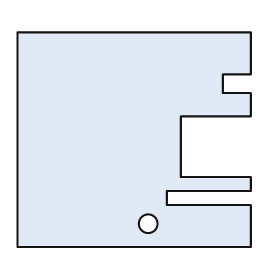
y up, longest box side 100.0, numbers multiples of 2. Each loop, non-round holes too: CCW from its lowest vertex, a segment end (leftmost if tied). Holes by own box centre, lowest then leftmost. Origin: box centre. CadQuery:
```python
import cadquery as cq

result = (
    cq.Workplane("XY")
    .moveTo(-50.0, -46.0)
    .lineTo(50.0, -46.0)
    .lineTo(50.0, -28.0)
    .lineTo(14.0, -28.0)
    .lineTo(14.0, -22.0)
    .lineTo(50.0, -22.0)
    .lineTo(50.0, -16.0)
    .lineTo(20.0, -16.0)
    .lineTo(20.0, 10.0)
    .lineTo(50.0, 10.0)
    .lineTo(50.0, 20.0)
    .lineTo(38.0, 20.0)
    .lineTo(38.0, 28.0)
    .lineTo(50.0, 28.0)
    .lineTo(50.0, 46.0)
    .lineTo(-50.0, 46.0)
    .close()
    .moveTo(6.0, -36.0)
    .circle(4.0)
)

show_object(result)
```